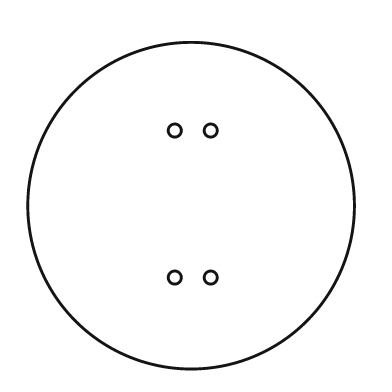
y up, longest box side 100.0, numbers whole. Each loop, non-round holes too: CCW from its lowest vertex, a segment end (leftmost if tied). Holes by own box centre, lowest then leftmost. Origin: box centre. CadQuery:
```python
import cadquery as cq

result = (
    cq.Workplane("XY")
    .moveTo(0.0, 0.0)
    .circle(50.0)
    .moveTo(-5.0, -22.0)
    .circle(2.0)
    .moveTo(6.0, -22.0)
    .circle(2.0)
    .moveTo(-5.0, 23.0)
    .circle(2.0)
    .moveTo(6.0, 23.0)
    .circle(2.0)
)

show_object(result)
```